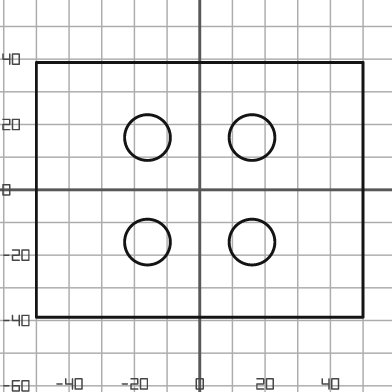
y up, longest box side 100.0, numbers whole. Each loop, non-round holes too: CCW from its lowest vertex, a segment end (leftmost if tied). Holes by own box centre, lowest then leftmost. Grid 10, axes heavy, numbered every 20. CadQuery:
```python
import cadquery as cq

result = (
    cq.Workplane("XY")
    .moveTo(-50.0, -39.0)
    .lineTo(50.0, -39.0)
    .lineTo(50.0, 39.0)
    .lineTo(-50.0, 39.0)
    .close()
    .moveTo(-16.0, -16.0)
    .circle(7.0)
    .moveTo(16.0, -16.0)
    .circle(7.0)
    .moveTo(-16.0, 16.0)
    .circle(7.0)
    .moveTo(16.0, 16.0)
    .circle(7.0)
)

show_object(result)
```